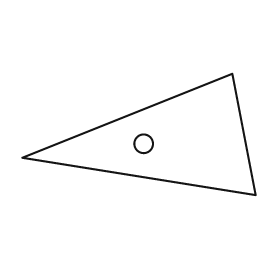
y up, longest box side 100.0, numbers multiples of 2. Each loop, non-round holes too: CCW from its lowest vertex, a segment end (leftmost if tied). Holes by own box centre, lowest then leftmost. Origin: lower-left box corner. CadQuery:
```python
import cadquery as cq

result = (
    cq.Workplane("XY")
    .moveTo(100.0, 0.0)
    .lineTo(90.0, 52.0)
    .lineTo(0.0, 16.0)
    .close()
    .moveTo(52.0, 22.0)
    .circle(4.0)
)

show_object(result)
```